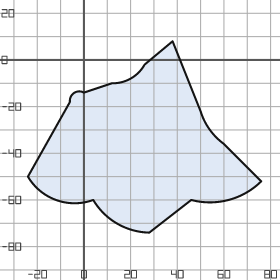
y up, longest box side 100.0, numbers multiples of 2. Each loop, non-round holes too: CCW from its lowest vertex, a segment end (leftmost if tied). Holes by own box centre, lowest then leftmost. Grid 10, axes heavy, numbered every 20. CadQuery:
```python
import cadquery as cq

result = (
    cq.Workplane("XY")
    .moveTo(28.0, -74.0)
    .lineTo(46.0, -60.0)
    .threePointArc((62.0, -60.0), (76.0, -52.0))
    .lineTo(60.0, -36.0)
    .threePointArc((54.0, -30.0), (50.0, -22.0))
    .lineTo(38.0, 8.0)
    .lineTo(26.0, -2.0)
    .threePointArc((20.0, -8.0), (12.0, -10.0))
    .lineTo(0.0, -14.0)
    .threePointArc((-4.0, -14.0), (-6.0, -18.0))
    .lineTo(-24.0, -50.0)
    .threePointArc((-12.0, -60.0), (4.0, -60.0))
    .threePointArc((14.0, -70.0), (28.0, -74.0))
    .close()
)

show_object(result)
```